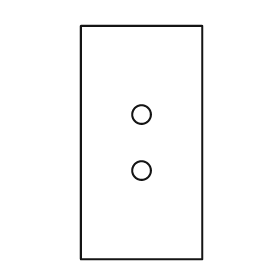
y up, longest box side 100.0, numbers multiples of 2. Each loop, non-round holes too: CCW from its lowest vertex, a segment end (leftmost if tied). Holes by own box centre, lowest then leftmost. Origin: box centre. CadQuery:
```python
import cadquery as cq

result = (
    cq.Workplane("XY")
    .moveTo(-26.0, -50.0)
    .lineTo(26.0, -50.0)
    .lineTo(26.0, 50.0)
    .lineTo(-26.0, 50.0)
    .close()
    .moveTo(0.0, -12.0)
    .circle(4.0)
    .moveTo(0.0, 12.0)
    .circle(4.0)
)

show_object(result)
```